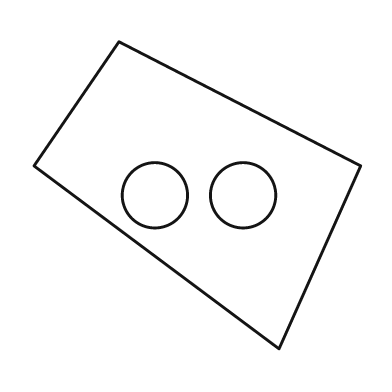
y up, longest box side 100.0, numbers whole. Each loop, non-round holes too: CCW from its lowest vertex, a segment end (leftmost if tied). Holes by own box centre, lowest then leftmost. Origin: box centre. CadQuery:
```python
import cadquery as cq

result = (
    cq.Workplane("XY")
    .moveTo(25.0, -47.0)
    .lineTo(50.0, 9.0)
    .lineTo(-24.0, 47.0)
    .lineTo(-50.0, 9.0)
    .close()
    .moveTo(-13.0, 0.0)
    .circle(10.0)
    .moveTo(14.0, 0.0)
    .circle(10.0)
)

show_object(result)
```